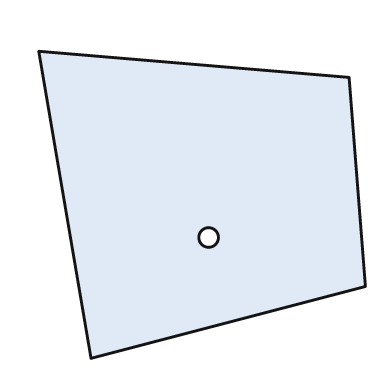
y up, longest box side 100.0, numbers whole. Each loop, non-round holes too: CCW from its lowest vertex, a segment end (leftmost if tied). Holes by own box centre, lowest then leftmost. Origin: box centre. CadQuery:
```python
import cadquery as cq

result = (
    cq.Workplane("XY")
    .moveTo(-34.0, -47.0)
    .lineTo(50.0, -25.0)
    .lineTo(45.0, 39.0)
    .lineTo(-50.0, 47.0)
    .close()
    .moveTo(2.0, -10.0)
    .circle(3.0)
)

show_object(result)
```